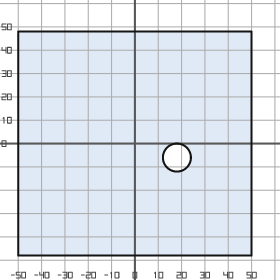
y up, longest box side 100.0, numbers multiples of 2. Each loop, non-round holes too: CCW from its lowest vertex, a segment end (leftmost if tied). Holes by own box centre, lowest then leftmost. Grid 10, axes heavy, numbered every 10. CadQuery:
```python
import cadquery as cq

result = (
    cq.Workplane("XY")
    .moveTo(-50.0, -48.0)
    .lineTo(50.0, -48.0)
    .lineTo(50.0, 48.0)
    .lineTo(-50.0, 48.0)
    .close()
    .moveTo(18.0, -6.0)
    .circle(6.0)
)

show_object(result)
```